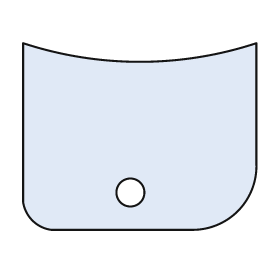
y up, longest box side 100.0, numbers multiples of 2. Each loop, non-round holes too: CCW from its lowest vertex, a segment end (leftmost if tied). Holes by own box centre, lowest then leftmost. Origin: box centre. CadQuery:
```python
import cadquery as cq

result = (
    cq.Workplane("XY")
    .moveTo(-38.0, -40.0)
    .lineTo(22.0, -40.0)
    .threePointArc((42.0, -32.0), (50.0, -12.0))
    .lineTo(50.0, 40.0)
    .threePointArc((0.0, 32.0), (-50.0, 40.0))
    .lineTo(-50.0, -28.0)
    .threePointArc((-46.0, -36.0), (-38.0, -40.0))
    .close()
    .moveTo(-4.0, -24.0)
    .circle(6.0)
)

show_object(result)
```